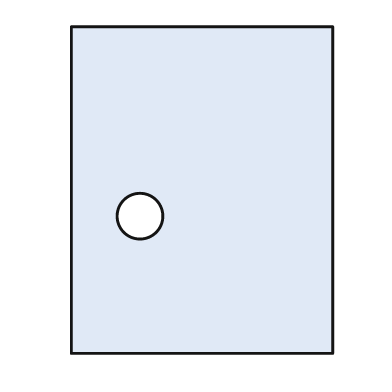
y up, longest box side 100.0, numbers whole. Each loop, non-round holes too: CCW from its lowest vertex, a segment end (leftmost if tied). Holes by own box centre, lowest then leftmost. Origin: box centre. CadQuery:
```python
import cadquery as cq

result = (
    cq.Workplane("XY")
    .moveTo(-40.0, -50.0)
    .lineTo(40.0, -50.0)
    .lineTo(40.0, 50.0)
    .lineTo(-40.0, 50.0)
    .close()
    .moveTo(-19.0, -8.0)
    .circle(7.0)
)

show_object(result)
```